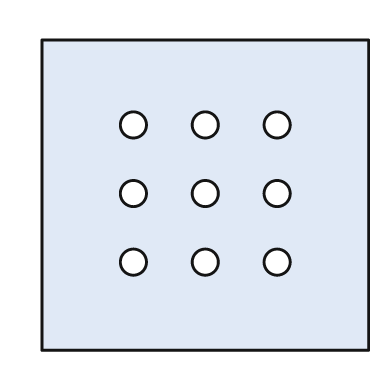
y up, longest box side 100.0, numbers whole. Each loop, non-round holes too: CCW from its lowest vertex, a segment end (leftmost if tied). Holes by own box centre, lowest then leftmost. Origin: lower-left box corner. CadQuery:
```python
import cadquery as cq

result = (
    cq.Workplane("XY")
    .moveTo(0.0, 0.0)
    .lineTo(100.0, 0.0)
    .lineTo(100.0, 95.0)
    .lineTo(0.0, 95.0)
    .close()
    .moveTo(28.0, 27.0)
    .circle(4.0)
    .moveTo(50.0, 27.0)
    .circle(4.0)
    .moveTo(72.0, 27.0)
    .circle(4.0)
    .moveTo(28.0, 48.0)
    .circle(4.0)
    .moveTo(50.0, 48.0)
    .circle(4.0)
    .moveTo(72.0, 48.0)
    .circle(4.0)
    .moveTo(28.0, 69.0)
    .circle(4.0)
    .moveTo(50.0, 69.0)
    .circle(4.0)
    .moveTo(72.0, 69.0)
    .circle(4.0)
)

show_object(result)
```